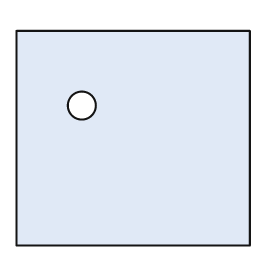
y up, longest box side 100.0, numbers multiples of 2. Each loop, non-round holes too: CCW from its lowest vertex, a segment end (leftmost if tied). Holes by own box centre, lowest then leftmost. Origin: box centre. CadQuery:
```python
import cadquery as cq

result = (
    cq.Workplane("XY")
    .moveTo(-50.0, -46.0)
    .lineTo(50.0, -46.0)
    .lineTo(50.0, 46.0)
    .lineTo(-50.0, 46.0)
    .close()
    .moveTo(-22.0, 14.0)
    .circle(6.0)
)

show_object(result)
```